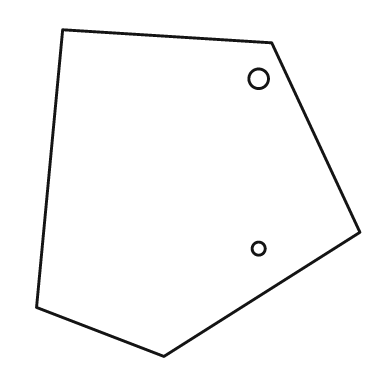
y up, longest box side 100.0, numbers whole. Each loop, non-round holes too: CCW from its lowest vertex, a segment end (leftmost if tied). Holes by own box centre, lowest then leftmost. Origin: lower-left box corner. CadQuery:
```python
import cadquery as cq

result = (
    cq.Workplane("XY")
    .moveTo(39.0, 0.0)
    .lineTo(99.0, 38.0)
    .lineTo(72.0, 96.0)
    .lineTo(8.0, 100.0)
    .lineTo(0.0, 15.0)
    .close()
    .moveTo(68.0, 33.0)
    .circle(2.0)
    .moveTo(68.0, 85.0)
    .circle(3.0)
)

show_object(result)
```